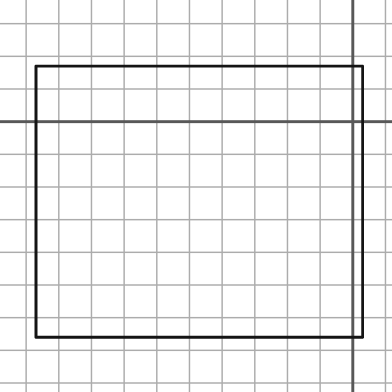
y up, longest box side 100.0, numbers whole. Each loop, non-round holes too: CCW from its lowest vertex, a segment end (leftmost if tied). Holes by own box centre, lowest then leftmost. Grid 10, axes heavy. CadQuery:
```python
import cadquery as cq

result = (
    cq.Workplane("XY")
    .moveTo(-97.0, -66.0)
    .lineTo(3.0, -66.0)
    .lineTo(3.0, 17.0)
    .lineTo(-97.0, 17.0)
    .close()
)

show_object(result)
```